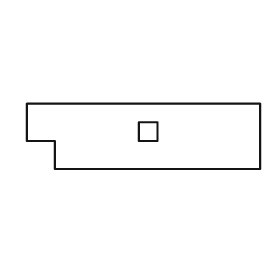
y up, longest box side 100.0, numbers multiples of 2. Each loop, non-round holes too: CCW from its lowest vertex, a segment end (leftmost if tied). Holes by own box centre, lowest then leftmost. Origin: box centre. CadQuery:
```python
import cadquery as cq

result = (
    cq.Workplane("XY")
    .moveTo(-38.0, -14.0)
    .lineTo(50.0, -14.0)
    .lineTo(50.0, 14.0)
    .lineTo(-50.0, 14.0)
    .lineTo(-50.0, -2.0)
    .lineTo(-38.0, -2.0)
    .close()
    .moveTo(-2.0, -2.0)
    .lineTo(6.0, -2.0)
    .lineTo(6.0, 6.0)
    .lineTo(-2.0, 6.0)
    .close()
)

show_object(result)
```